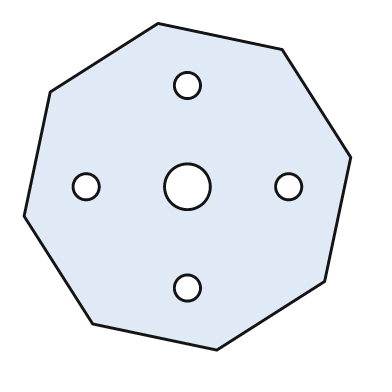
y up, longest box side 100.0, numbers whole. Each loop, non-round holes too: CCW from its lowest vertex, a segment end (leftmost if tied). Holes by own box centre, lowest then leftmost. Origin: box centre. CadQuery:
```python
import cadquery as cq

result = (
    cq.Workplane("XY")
    .moveTo(9.0, -50.0)
    .lineTo(42.0, -29.0)
    .lineTo(50.0, 9.0)
    .lineTo(29.0, 42.0)
    .lineTo(-9.0, 50.0)
    .lineTo(-42.0, 29.0)
    .lineTo(-50.0, -9.0)
    .lineTo(-29.0, -42.0)
    .close()
    .moveTo(0.0, -31.0)
    .circle(4.0)
    .moveTo(-31.0, 0.0)
    .circle(4.0)
    .moveTo(0.0, 0.0)
    .circle(7.0)
    .moveTo(31.0, 0.0)
    .circle(4.0)
    .moveTo(0.0, 31.0)
    .circle(4.0)
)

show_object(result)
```